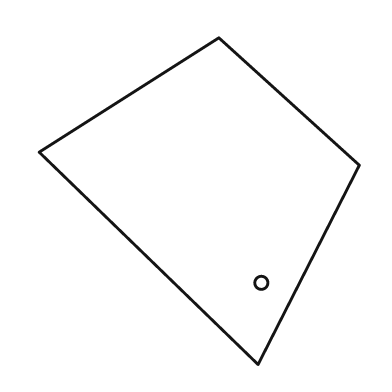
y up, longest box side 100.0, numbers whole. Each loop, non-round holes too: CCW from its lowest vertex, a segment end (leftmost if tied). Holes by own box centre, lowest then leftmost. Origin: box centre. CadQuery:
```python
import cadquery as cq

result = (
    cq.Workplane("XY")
    .moveTo(18.0, -50.0)
    .lineTo(49.0, 11.0)
    .lineTo(6.0, 50.0)
    .lineTo(-49.0, 15.0)
    .close()
    .moveTo(19.0, -25.0)
    .circle(2.0)
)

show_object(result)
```